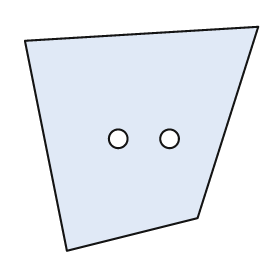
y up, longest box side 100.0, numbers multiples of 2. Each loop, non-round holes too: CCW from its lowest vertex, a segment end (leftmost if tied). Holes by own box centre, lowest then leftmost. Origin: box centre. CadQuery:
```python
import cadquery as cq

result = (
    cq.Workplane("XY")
    .moveTo(-32.0, -48.0)
    .lineTo(24.0, -34.0)
    .lineTo(50.0, 48.0)
    .lineTo(-50.0, 42.0)
    .close()
    .moveTo(-10.0, 0.0)
    .circle(4.0)
    .moveTo(12.0, 0.0)
    .circle(4.0)
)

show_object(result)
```